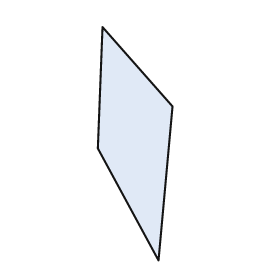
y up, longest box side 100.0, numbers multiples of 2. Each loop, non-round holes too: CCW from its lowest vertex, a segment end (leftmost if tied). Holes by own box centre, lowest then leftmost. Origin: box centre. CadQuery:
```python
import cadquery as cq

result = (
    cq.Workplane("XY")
    .moveTo(10.0, -50.0)
    .lineTo(16.0, 16.0)
    .lineTo(-14.0, 50.0)
    .lineTo(-16.0, -2.0)
    .close()
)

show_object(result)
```